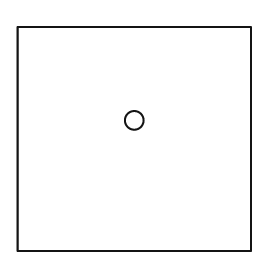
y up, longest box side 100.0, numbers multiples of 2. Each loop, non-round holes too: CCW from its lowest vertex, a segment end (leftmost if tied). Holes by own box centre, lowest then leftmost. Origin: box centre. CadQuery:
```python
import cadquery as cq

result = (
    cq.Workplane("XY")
    .moveTo(-50.0, -48.0)
    .lineTo(50.0, -48.0)
    .lineTo(50.0, 48.0)
    .lineTo(-50.0, 48.0)
    .close()
    .moveTo(0.0, 8.0)
    .circle(4.0)
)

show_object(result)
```